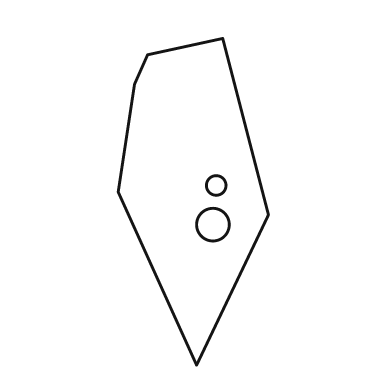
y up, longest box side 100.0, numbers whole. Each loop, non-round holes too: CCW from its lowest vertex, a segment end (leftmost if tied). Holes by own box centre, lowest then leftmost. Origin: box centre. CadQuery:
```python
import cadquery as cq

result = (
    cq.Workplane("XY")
    .moveTo(1.0, -50.0)
    .lineTo(23.0, -4.0)
    .lineTo(9.0, 50.0)
    .lineTo(-14.0, 45.0)
    .lineTo(-18.0, 36.0)
    .lineTo(-23.0, 3.0)
    .close()
    .moveTo(6.0, -7.0)
    .circle(5.0)
    .moveTo(7.0, 5.0)
    .circle(3.0)
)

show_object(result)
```